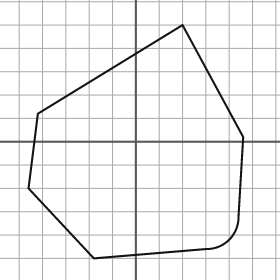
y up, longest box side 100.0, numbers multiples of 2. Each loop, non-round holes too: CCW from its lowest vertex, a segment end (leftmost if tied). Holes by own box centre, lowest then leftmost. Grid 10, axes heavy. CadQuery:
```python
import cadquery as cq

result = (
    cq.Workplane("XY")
    .moveTo(-18.0, -50.0)
    .lineTo(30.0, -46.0)
    .threePointArc((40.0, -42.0), (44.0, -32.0))
    .lineTo(46.0, 2.0)
    .lineTo(20.0, 50.0)
    .lineTo(-42.0, 12.0)
    .lineTo(-46.0, -20.0)
    .close()
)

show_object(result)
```